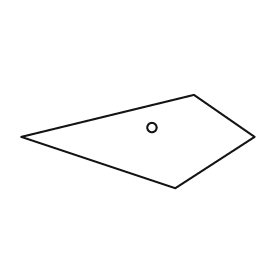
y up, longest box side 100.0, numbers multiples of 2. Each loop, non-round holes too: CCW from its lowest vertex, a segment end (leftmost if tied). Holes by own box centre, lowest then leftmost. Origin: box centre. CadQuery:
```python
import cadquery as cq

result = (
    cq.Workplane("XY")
    .moveTo(16.0, -20.0)
    .lineTo(50.0, 2.0)
    .lineTo(24.0, 20.0)
    .lineTo(-50.0, 2.0)
    .close()
    .moveTo(6.0, 6.0)
    .circle(2.0)
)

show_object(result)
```